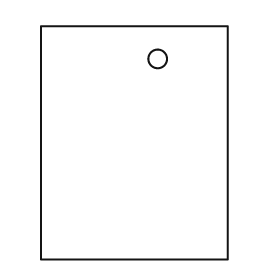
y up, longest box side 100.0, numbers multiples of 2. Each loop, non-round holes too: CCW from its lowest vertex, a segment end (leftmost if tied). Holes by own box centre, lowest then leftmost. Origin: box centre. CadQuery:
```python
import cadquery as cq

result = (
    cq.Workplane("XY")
    .moveTo(-40.0, -50.0)
    .lineTo(40.0, -50.0)
    .lineTo(40.0, 50.0)
    .lineTo(-40.0, 50.0)
    .close()
    .moveTo(10.0, 36.0)
    .circle(4.0)
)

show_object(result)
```